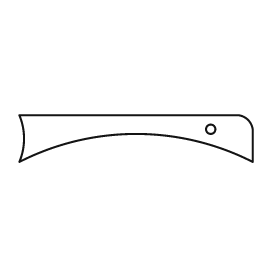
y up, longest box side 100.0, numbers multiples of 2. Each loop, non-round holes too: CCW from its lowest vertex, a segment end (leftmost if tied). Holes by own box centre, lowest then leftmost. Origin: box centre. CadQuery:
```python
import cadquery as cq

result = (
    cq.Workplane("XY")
    .moveTo(-50.0, -10.0)
    .threePointArc((0.0, 2.0), (50.0, -10.0))
    .lineTo(50.0, 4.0)
    .threePointArc((48.0, 8.0), (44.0, 10.0))
    .lineTo(-50.0, 10.0)
    .threePointArc((-48.0, 0.0), (-50.0, -10.0))
    .close()
    .moveTo(32.0, 4.0)
    .circle(2.0)
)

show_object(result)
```